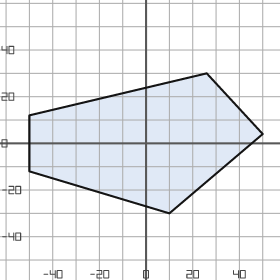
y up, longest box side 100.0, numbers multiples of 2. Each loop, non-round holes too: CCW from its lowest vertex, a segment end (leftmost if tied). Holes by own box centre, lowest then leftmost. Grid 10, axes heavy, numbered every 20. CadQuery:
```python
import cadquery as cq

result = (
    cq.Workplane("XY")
    .moveTo(10.0, -30.0)
    .lineTo(50.0, 4.0)
    .lineTo(26.0, 30.0)
    .lineTo(-50.0, 12.0)
    .lineTo(-50.0, -12.0)
    .close()
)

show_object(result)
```